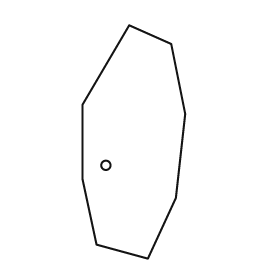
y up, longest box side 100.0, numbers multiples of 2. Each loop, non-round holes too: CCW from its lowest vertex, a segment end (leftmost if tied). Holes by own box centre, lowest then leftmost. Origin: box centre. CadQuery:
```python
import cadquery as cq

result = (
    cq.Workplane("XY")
    .moveTo(6.0, -50.0)
    .lineTo(18.0, -24.0)
    .lineTo(22.0, 12.0)
    .lineTo(16.0, 42.0)
    .lineTo(-2.0, 50.0)
    .lineTo(-22.0, 16.0)
    .lineTo(-22.0, -16.0)
    .lineTo(-16.0, -44.0)
    .close()
    .moveTo(-12.0, -10.0)
    .circle(2.0)
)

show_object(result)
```